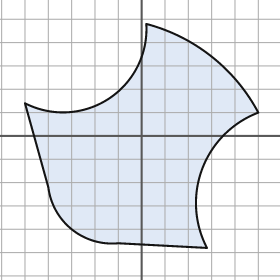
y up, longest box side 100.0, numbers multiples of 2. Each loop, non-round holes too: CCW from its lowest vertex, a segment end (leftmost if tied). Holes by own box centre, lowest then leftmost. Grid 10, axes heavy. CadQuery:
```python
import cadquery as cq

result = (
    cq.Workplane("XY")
    .moveTo(28.0, -48.0)
    .threePointArc((26.0, -14.0), (50.0, 10.0))
    .threePointArc((30.0, 34.0), (2.0, 48.0))
    .threePointArc((-14.0, 16.0), (-50.0, 14.0))
    .lineTo(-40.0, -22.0)
    .threePointArc((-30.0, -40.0), (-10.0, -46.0))
    .close()
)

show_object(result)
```